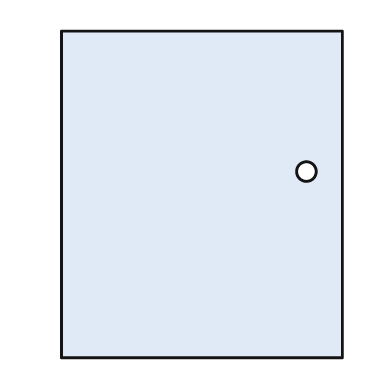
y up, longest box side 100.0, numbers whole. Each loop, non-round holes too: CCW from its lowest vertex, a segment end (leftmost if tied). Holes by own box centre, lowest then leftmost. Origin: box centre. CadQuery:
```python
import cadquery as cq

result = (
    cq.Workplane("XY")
    .moveTo(-43.0, -50.0)
    .lineTo(43.0, -50.0)
    .lineTo(43.0, 50.0)
    .lineTo(-43.0, 50.0)
    .close()
    .moveTo(32.0, 7.0)
    .circle(3.0)
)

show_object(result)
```